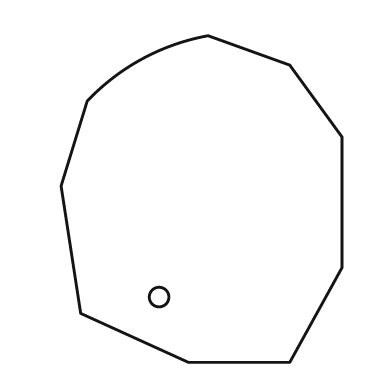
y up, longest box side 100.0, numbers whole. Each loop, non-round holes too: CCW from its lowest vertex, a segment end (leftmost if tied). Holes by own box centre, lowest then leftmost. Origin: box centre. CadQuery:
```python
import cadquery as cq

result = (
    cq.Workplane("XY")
    .moveTo(-4.0, -50.0)
    .lineTo(27.0, -50.0)
    .lineTo(43.0, -21.0)
    .lineTo(43.0, 19.0)
    .lineTo(27.0, 41.0)
    .lineTo(2.0, 50.0)
    .threePointArc((-18.0, 43.0), (-35.0, 30.0))
    .lineTo(-43.0, 4.0)
    .lineTo(-37.0, -35.0)
    .close()
    .moveTo(-13.0, -30.0)
    .circle(3.0)
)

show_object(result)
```